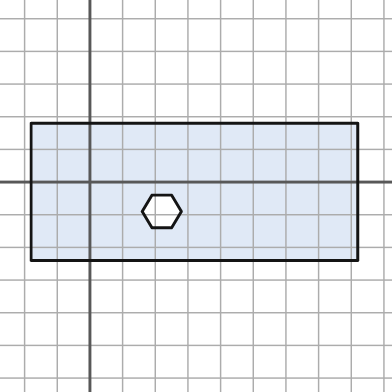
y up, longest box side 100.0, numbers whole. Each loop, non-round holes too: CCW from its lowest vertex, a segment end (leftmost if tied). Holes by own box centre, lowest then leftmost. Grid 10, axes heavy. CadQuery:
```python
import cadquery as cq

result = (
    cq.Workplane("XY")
    .moveTo(-18.0, -24.0)
    .lineTo(82.0, -24.0)
    .lineTo(82.0, 18.0)
    .lineTo(-18.0, 18.0)
    .close()
    .moveTo(19.0, -14.0)
    .lineTo(25.0, -14.0)
    .lineTo(28.0, -9.0)
    .lineTo(25.0, -4.0)
    .lineTo(19.0, -4.0)
    .lineTo(16.0, -9.0)
    .close()
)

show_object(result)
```